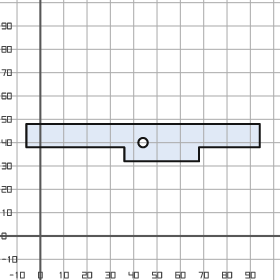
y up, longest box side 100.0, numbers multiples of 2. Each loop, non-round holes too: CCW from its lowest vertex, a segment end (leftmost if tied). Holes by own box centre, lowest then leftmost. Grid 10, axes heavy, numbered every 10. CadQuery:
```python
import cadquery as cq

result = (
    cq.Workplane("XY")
    .moveTo(36.0, 32.0)
    .lineTo(68.0, 32.0)
    .lineTo(68.0, 38.0)
    .lineTo(94.0, 38.0)
    .lineTo(94.0, 48.0)
    .lineTo(-6.0, 48.0)
    .lineTo(-6.0, 38.0)
    .lineTo(36.0, 38.0)
    .close()
    .moveTo(44.0, 40.0)
    .circle(2.0)
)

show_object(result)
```